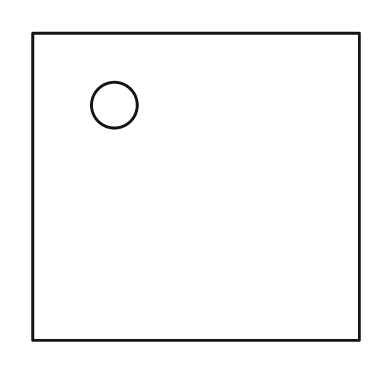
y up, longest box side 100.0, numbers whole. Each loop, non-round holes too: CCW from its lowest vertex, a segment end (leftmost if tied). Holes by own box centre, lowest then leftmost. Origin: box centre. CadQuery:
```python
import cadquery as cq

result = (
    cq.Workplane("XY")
    .moveTo(-50.0, -47.0)
    .lineTo(50.0, -47.0)
    .lineTo(50.0, 47.0)
    .lineTo(-50.0, 47.0)
    .close()
    .moveTo(-25.0, 25.0)
    .circle(7.0)
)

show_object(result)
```